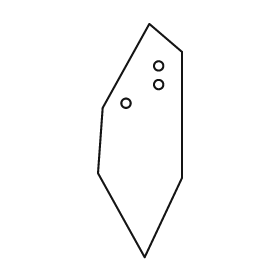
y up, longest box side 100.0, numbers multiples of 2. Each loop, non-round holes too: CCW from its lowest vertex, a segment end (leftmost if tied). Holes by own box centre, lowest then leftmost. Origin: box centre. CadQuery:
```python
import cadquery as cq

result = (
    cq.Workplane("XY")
    .moveTo(2.0, -50.0)
    .lineTo(18.0, -16.0)
    .lineTo(18.0, 38.0)
    .lineTo(4.0, 50.0)
    .lineTo(-16.0, 14.0)
    .lineTo(-18.0, -14.0)
    .close()
    .moveTo(-6.0, 16.0)
    .circle(2.0)
    .moveTo(8.0, 24.0)
    .circle(2.0)
    .moveTo(8.0, 32.0)
    .circle(2.0)
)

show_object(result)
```